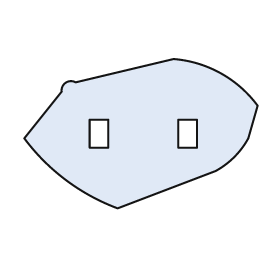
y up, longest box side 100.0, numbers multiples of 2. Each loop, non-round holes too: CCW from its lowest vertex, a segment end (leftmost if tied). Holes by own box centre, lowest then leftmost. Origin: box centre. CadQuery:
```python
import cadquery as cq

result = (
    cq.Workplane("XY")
    .moveTo(-10.0, -32.0)
    .lineTo(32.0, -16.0)
    .threePointArc((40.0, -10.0), (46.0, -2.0))
    .lineTo(50.0, 12.0)
    .threePointArc((34.0, 26.0), (14.0, 32.0))
    .lineTo(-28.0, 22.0)
    .threePointArc((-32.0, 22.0), (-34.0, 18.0))
    .lineTo(-50.0, -2.0)
    .threePointArc((-32.0, -20.0), (-10.0, -32.0))
    .close()
    .moveTo(-22.0, -6.0)
    .lineTo(-14.0, -6.0)
    .lineTo(-14.0, 6.0)
    .lineTo(-22.0, 6.0)
    .close()
    .moveTo(16.0, -6.0)
    .lineTo(24.0, -6.0)
    .lineTo(24.0, 6.0)
    .lineTo(16.0, 6.0)
    .close()
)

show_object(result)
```